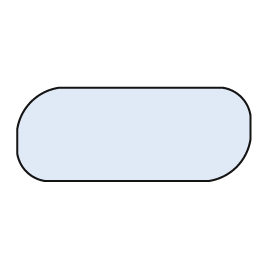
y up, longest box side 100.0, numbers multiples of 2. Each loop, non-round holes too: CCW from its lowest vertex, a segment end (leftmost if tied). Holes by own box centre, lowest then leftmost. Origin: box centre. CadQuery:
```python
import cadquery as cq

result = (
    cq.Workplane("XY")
    .moveTo(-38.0, -20.0)
    .lineTo(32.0, -20.0)
    .threePointArc((44.0, -14.0), (50.0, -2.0))
    .lineTo(50.0, 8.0)
    .threePointArc((46.0, 16.0), (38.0, 20.0))
    .lineTo(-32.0, 20.0)
    .threePointArc((-44.0, 14.0), (-50.0, 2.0))
    .lineTo(-50.0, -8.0)
    .threePointArc((-46.0, -16.0), (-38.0, -20.0))
    .close()
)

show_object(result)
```